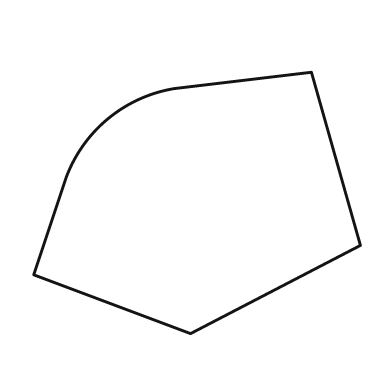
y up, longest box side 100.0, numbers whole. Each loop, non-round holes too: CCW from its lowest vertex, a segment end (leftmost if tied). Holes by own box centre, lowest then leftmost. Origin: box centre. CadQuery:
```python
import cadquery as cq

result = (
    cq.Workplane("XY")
    .moveTo(-2.0, -40.0)
    .lineTo(50.0, -13.0)
    .lineTo(35.0, 40.0)
    .lineTo(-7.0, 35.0)
    .threePointArc((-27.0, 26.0), (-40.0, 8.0))
    .lineTo(-50.0, -22.0)
    .close()
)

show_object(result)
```